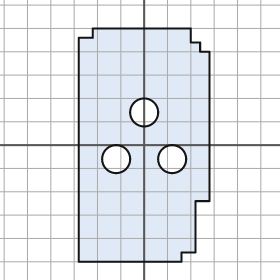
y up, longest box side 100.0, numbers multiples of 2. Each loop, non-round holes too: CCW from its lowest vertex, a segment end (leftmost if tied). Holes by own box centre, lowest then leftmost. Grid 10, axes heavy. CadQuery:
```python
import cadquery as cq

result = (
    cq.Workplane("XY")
    .moveTo(-28.0, -50.0)
    .lineTo(16.0, -50.0)
    .lineTo(16.0, -46.0)
    .lineTo(22.0, -46.0)
    .lineTo(22.0, -24.0)
    .lineTo(28.0, -24.0)
    .lineTo(28.0, 40.0)
    .lineTo(24.0, 40.0)
    .lineTo(24.0, 44.0)
    .lineTo(20.0, 44.0)
    .lineTo(20.0, 50.0)
    .lineTo(-22.0, 50.0)
    .lineTo(-22.0, 46.0)
    .lineTo(-28.0, 46.0)
    .close()
    .moveTo(-12.0, -6.0)
    .circle(6.0)
    .moveTo(12.0, -6.0)
    .circle(6.0)
    .moveTo(0.0, 14.0)
    .circle(6.0)
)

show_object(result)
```